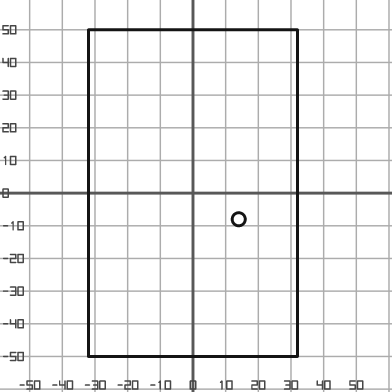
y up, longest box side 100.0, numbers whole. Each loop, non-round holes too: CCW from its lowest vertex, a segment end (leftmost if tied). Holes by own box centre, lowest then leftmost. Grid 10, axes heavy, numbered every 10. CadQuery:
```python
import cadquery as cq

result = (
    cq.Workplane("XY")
    .moveTo(-32.0, -50.0)
    .lineTo(32.0, -50.0)
    .lineTo(32.0, 50.0)
    .lineTo(-32.0, 50.0)
    .close()
    .moveTo(14.0, -8.0)
    .circle(2.0)
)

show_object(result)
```